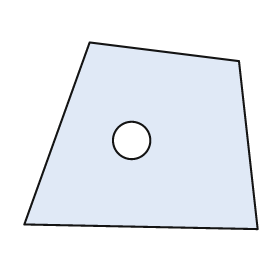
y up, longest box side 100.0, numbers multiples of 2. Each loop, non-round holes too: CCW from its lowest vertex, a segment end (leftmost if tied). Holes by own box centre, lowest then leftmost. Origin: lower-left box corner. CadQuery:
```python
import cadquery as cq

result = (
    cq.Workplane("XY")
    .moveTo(100.0, 0.0)
    .lineTo(92.0, 72.0)
    .lineTo(28.0, 80.0)
    .lineTo(0.0, 2.0)
    .close()
    .moveTo(46.0, 38.0)
    .circle(8.0)
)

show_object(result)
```